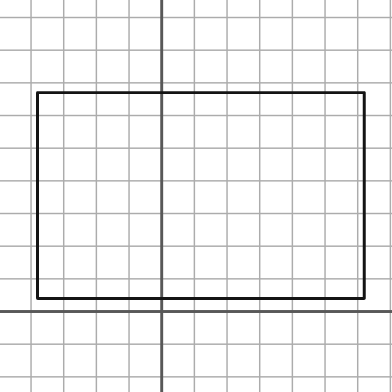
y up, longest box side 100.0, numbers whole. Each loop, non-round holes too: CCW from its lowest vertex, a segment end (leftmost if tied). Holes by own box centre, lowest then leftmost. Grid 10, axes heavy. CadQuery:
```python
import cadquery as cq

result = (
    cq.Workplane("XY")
    .moveTo(-38.0, 4.0)
    .lineTo(62.0, 4.0)
    .lineTo(62.0, 67.0)
    .lineTo(-38.0, 67.0)
    .close()
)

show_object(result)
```